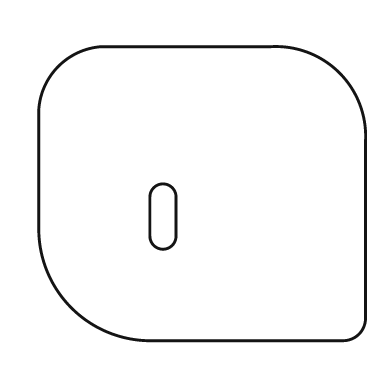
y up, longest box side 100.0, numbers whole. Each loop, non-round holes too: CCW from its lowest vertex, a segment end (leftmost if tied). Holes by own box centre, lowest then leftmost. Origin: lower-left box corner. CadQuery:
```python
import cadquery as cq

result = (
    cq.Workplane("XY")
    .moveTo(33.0, 0.0)
    .lineTo(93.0, 0.0)
    .threePointArc((98.0, 2.0), (100.0, 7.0))
    .lineTo(100.0, 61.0)
    .threePointArc((92.0, 82.0), (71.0, 90.0))
    .lineTo(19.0, 90.0)
    .threePointArc((6.0, 84.0), (0.0, 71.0))
    .lineTo(0.0, 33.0)
    .threePointArc((10.0, 10.0), (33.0, 0.0))
    .close()
    .moveTo(34.0, 32.0)
    .threePointArc((38.0, 28.0), (42.0, 32.0))
    .lineTo(42.0, 44.0)
    .threePointArc((38.0, 48.0), (34.0, 44.0))
    .close()
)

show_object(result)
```